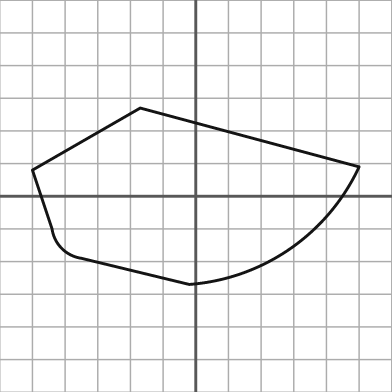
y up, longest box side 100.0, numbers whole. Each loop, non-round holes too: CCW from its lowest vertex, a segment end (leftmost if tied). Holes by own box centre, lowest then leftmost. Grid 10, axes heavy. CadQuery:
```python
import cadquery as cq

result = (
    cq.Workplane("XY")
    .moveTo(-2.0, -27.0)
    .threePointArc((29.0, -16.0), (50.0, 9.0))
    .lineTo(-17.0, 27.0)
    .lineTo(-50.0, 8.0)
    .lineTo(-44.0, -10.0)
    .threePointArc((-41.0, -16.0), (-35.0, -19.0))
    .close()
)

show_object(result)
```